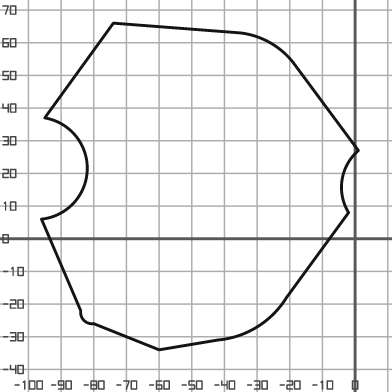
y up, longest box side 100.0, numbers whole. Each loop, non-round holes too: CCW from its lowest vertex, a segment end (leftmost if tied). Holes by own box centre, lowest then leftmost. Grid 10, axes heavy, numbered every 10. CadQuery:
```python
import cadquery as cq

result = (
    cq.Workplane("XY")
    .moveTo(-60.0, -34.0)
    .lineTo(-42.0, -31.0)
    .threePointArc((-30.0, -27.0), (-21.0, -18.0))
    .lineTo(-2.0, 8.0)
    .threePointArc((-4.0, 18.0), (1.0, 27.0))
    .lineTo(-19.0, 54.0)
    .threePointArc((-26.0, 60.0), (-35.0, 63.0))
    .lineTo(-74.0, 66.0)
    .lineTo(-95.0, 37.0)
    .threePointArc((-82.0, 21.0), (-96.0, 6.0))
    .lineTo(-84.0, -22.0)
    .threePointArc((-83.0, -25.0), (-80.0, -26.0))
    .close()
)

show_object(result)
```